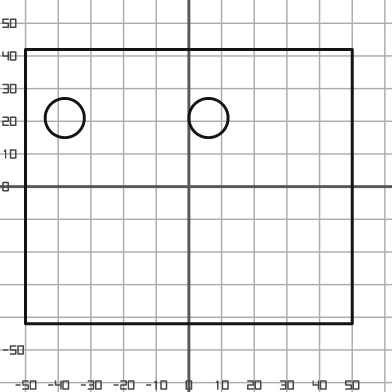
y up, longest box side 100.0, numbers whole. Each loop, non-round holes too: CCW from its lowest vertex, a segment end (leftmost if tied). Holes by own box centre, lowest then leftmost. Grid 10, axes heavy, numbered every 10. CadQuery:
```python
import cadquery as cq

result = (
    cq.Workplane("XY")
    .moveTo(-50.0, -42.0)
    .lineTo(50.0, -42.0)
    .lineTo(50.0, 42.0)
    .lineTo(-50.0, 42.0)
    .close()
    .moveTo(-38.0, 21.0)
    .circle(6.0)
    .moveTo(6.0, 21.0)
    .circle(6.0)
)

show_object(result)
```